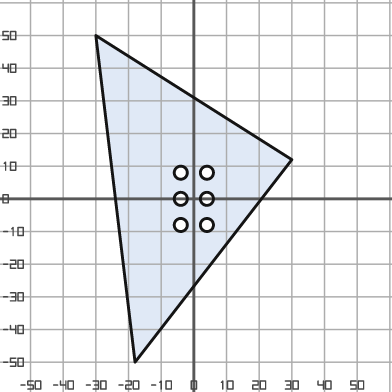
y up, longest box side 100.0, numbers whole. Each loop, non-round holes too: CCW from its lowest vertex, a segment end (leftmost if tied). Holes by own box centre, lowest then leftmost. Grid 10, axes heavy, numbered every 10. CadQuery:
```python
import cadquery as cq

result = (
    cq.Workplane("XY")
    .moveTo(-18.0, -50.0)
    .lineTo(30.0, 12.0)
    .lineTo(-30.0, 50.0)
    .close()
    .moveTo(-4.0, -8.0)
    .circle(2.0)
    .moveTo(4.0, -8.0)
    .circle(2.0)
    .moveTo(-4.0, 0.0)
    .circle(2.0)
    .moveTo(4.0, 0.0)
    .circle(2.0)
    .moveTo(-4.0, 8.0)
    .circle(2.0)
    .moveTo(4.0, 8.0)
    .circle(2.0)
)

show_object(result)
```